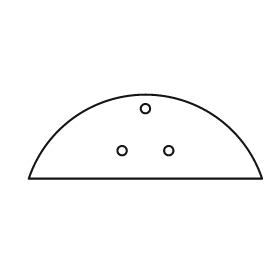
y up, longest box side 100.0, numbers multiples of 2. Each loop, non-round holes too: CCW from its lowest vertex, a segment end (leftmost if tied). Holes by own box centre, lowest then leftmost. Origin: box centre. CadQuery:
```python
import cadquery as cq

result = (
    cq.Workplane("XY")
    .moveTo(-50.0, -18.0)
    .lineTo(50.0, -18.0)
    .threePointArc((0.0, 18.0), (-50.0, -18.0))
    .close()
    .moveTo(-10.0, -6.0)
    .circle(2.0)
    .moveTo(10.0, -6.0)
    .circle(2.0)
    .moveTo(0.0, 12.0)
    .circle(2.0)
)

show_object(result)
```